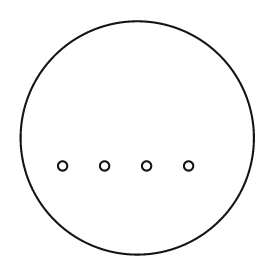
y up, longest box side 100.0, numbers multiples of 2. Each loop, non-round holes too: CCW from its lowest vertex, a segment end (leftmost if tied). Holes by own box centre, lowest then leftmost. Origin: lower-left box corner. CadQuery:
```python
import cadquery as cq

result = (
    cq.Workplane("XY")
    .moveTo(50.0, 50.0)
    .circle(50.0)
    .moveTo(18.0, 38.0)
    .circle(2.0)
    .moveTo(36.0, 38.0)
    .circle(2.0)
    .moveTo(54.0, 38.0)
    .circle(2.0)
    .moveTo(72.0, 38.0)
    .circle(2.0)
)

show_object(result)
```